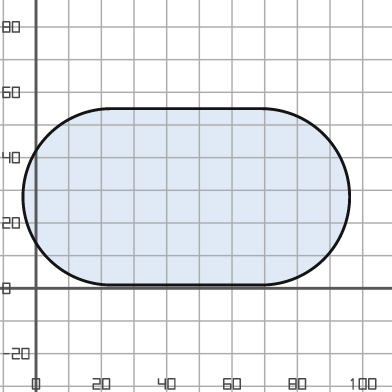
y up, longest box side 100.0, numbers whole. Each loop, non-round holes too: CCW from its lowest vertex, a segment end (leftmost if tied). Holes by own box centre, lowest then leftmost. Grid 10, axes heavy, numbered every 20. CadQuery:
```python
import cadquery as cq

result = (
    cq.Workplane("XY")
    .moveTo(23.0, 1.0)
    .lineTo(69.0, 1.0)
    .threePointArc((96.0, 28.0), (69.0, 55.0))
    .lineTo(23.0, 55.0)
    .threePointArc((-4.0, 28.0), (23.0, 1.0))
    .close()
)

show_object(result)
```